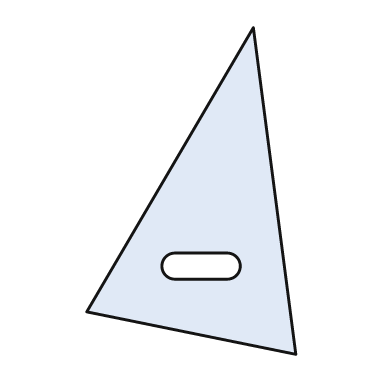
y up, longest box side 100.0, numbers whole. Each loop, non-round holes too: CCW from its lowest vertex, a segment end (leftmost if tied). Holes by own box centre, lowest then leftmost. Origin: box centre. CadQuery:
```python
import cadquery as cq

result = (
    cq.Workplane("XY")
    .moveTo(32.0, -50.0)
    .lineTo(19.0, 50.0)
    .lineTo(-32.0, -37.0)
    .close()
    .moveTo(-5.0, -27.0)
    .lineTo(11.0, -27.0)
    .threePointArc((15.0, -23.0), (11.0, -19.0))
    .lineTo(-5.0, -19.0)
    .threePointArc((-9.0, -23.0), (-5.0, -27.0))
    .close()
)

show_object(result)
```